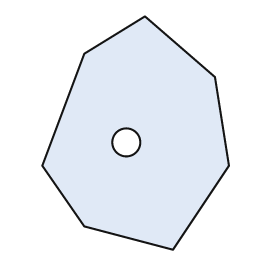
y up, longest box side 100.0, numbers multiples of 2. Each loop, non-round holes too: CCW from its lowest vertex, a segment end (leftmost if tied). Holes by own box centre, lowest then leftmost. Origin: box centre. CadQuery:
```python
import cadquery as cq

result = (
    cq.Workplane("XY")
    .moveTo(16.0, -50.0)
    .lineTo(40.0, -14.0)
    .lineTo(34.0, 24.0)
    .lineTo(4.0, 50.0)
    .lineTo(-22.0, 34.0)
    .lineTo(-40.0, -14.0)
    .lineTo(-22.0, -40.0)
    .close()
    .moveTo(-4.0, -4.0)
    .circle(6.0)
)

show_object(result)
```